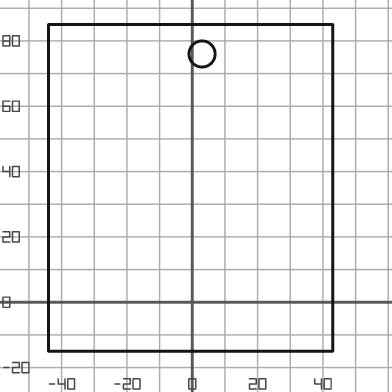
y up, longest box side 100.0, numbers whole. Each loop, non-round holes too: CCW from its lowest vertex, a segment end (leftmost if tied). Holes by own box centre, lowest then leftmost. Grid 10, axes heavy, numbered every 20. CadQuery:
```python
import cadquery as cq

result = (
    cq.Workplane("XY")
    .moveTo(-44.0, -15.0)
    .lineTo(43.0, -15.0)
    .lineTo(43.0, 85.0)
    .lineTo(-44.0, 85.0)
    .close()
    .moveTo(3.0, 76.0)
    .circle(4.0)
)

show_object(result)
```